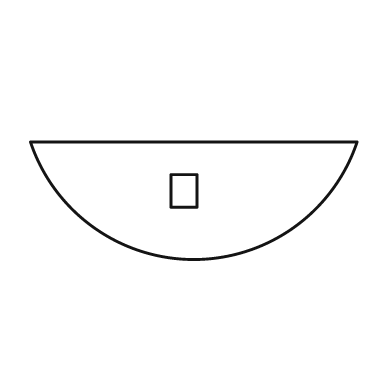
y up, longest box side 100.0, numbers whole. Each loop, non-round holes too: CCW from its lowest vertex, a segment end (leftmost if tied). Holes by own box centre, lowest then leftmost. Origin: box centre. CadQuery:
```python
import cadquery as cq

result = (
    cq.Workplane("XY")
    .moveTo(-50.0, 18.0)
    .threePointArc((0.0, -18.0), (50.0, 18.0))
    .close()
    .moveTo(-7.0, -2.0)
    .lineTo(1.0, -2.0)
    .lineTo(1.0, 8.0)
    .lineTo(-7.0, 8.0)
    .close()
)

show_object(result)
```